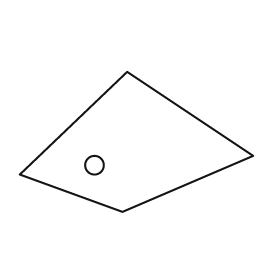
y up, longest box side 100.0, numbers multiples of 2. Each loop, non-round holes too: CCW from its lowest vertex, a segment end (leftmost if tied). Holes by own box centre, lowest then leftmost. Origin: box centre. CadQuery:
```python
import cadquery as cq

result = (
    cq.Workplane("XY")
    .moveTo(-6.0, -30.0)
    .lineTo(50.0, -6.0)
    .lineTo(-4.0, 30.0)
    .lineTo(-50.0, -14.0)
    .close()
    .moveTo(-18.0, -10.0)
    .circle(4.0)
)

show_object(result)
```